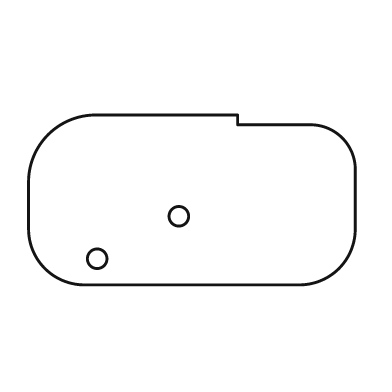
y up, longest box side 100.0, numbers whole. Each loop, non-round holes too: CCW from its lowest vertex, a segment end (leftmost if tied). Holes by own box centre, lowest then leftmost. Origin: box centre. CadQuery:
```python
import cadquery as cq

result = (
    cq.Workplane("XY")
    .moveTo(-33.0, -26.0)
    .lineTo(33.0, -26.0)
    .threePointArc((45.0, -21.0), (50.0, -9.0))
    .lineTo(50.0, 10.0)
    .threePointArc((46.0, 19.0), (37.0, 23.0))
    .lineTo(14.0, 23.0)
    .lineTo(14.0, 26.0)
    .lineTo(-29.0, 26.0)
    .threePointArc((-44.0, 20.0), (-50.0, 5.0))
    .lineTo(-50.0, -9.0)
    .threePointArc((-45.0, -21.0), (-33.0, -26.0))
    .close()
    .moveTo(-29.0, -18.0)
    .circle(3.0)
    .moveTo(-4.0, -5.0)
    .circle(3.0)
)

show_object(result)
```